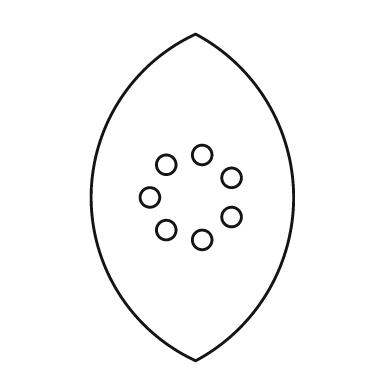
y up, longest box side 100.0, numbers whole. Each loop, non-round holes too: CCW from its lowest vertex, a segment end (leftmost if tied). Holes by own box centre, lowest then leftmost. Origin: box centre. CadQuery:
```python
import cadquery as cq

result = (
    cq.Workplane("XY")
    .moveTo(1.0, -50.0)
    .threePointArc((31.0, 0.0), (1.0, 50.0))
    .threePointArc((-31.0, 0.0), (1.0, -50.0))
    .close()
    .moveTo(3.0, -13.0)
    .circle(3.0)
    .moveTo(-8.0, -10.0)
    .circle(3.0)
    .moveTo(12.0, -6.0)
    .circle(3.0)
    .moveTo(-13.0, 0.0)
    .circle(3.0)
    .moveTo(12.0, 6.0)
    .circle(3.0)
    .moveTo(-8.0, 10.0)
    .circle(3.0)
    .moveTo(3.0, 13.0)
    .circle(3.0)
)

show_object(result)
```